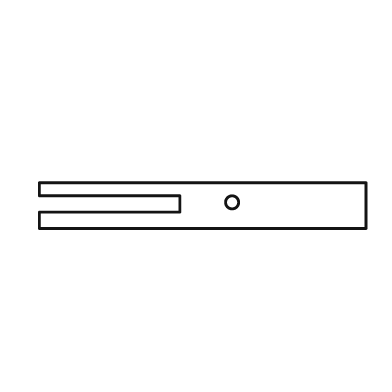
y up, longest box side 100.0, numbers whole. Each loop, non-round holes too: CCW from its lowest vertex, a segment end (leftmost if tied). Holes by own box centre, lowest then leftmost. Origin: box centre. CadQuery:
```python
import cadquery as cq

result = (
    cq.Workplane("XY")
    .moveTo(-50.0, -7.0)
    .lineTo(50.0, -7.0)
    .lineTo(50.0, 7.0)
    .lineTo(-50.0, 7.0)
    .lineTo(-50.0, 3.0)
    .lineTo(-7.0, 3.0)
    .lineTo(-7.0, -2.0)
    .lineTo(-50.0, -2.0)
    .close()
    .moveTo(9.0, 1.0)
    .circle(2.0)
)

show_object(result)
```